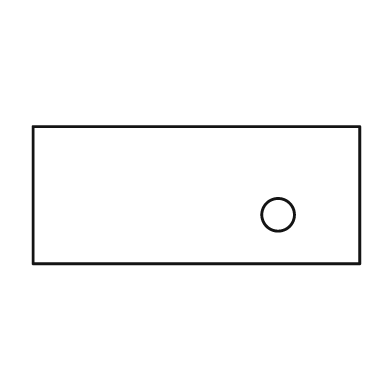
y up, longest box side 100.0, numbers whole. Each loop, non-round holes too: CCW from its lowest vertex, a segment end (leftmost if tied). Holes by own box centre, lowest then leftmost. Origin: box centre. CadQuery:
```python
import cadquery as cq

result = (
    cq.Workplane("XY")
    .moveTo(-50.0, -21.0)
    .lineTo(50.0, -21.0)
    .lineTo(50.0, 21.0)
    .lineTo(-50.0, 21.0)
    .close()
    .moveTo(25.0, -6.0)
    .circle(5.0)
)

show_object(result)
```